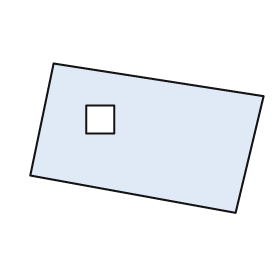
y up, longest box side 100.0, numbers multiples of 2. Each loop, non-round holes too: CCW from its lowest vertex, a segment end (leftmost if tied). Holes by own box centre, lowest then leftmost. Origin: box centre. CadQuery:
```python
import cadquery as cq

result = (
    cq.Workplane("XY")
    .moveTo(38.0, -32.0)
    .lineTo(50.0, 18.0)
    .lineTo(-40.0, 32.0)
    .lineTo(-50.0, -16.0)
    .close()
    .moveTo(-26.0, 2.0)
    .lineTo(-14.0, 2.0)
    .lineTo(-14.0, 14.0)
    .lineTo(-26.0, 14.0)
    .close()
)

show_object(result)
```